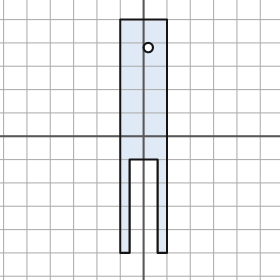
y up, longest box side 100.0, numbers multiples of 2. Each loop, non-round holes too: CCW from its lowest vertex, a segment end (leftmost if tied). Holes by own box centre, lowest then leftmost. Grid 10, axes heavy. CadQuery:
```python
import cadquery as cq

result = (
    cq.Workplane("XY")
    .moveTo(-10.0, -50.0)
    .lineTo(-6.0, -50.0)
    .lineTo(-6.0, -10.0)
    .lineTo(6.0, -10.0)
    .lineTo(6.0, -50.0)
    .lineTo(10.0, -50.0)
    .lineTo(10.0, 50.0)
    .lineTo(-10.0, 50.0)
    .close()
    .moveTo(2.0, 38.0)
    .circle(2.0)
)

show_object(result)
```